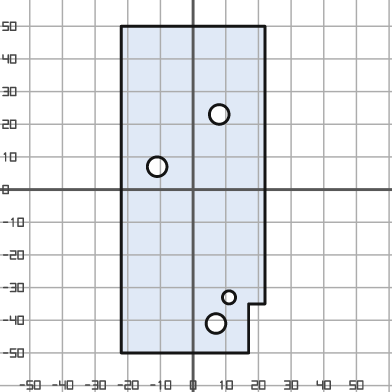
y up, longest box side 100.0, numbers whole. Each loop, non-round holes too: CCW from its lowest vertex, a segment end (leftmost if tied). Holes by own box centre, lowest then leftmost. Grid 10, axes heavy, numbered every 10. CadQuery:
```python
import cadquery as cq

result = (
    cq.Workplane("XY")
    .moveTo(-22.0, -50.0)
    .lineTo(17.0, -50.0)
    .lineTo(17.0, -35.0)
    .lineTo(22.0, -35.0)
    .lineTo(22.0, 50.0)
    .lineTo(-22.0, 50.0)
    .close()
    .moveTo(7.0, -41.0)
    .circle(3.0)
    .moveTo(11.0, -33.0)
    .circle(2.0)
    .moveTo(-11.0, 7.0)
    .circle(3.0)
    .moveTo(8.0, 23.0)
    .circle(3.0)
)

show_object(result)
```